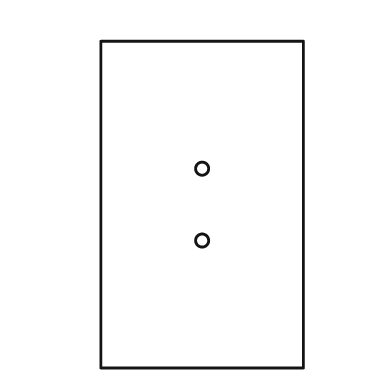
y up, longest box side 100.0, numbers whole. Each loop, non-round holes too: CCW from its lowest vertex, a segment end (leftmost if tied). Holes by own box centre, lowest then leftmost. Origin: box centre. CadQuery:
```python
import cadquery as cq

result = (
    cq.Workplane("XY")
    .moveTo(-31.0, -50.0)
    .lineTo(31.0, -50.0)
    .lineTo(31.0, 50.0)
    .lineTo(-31.0, 50.0)
    .close()
    .moveTo(0.0, -11.0)
    .circle(2.0)
    .moveTo(0.0, 11.0)
    .circle(2.0)
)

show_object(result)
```